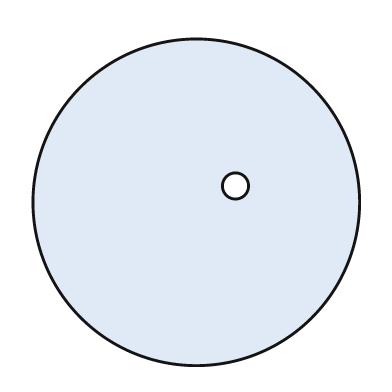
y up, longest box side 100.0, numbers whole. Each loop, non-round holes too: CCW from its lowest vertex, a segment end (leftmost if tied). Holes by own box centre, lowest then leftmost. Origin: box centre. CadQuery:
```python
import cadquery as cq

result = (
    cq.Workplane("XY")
    .moveTo(0.0, 0.0)
    .circle(50.0)
    .moveTo(12.0, 5.0)
    .circle(4.0)
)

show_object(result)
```